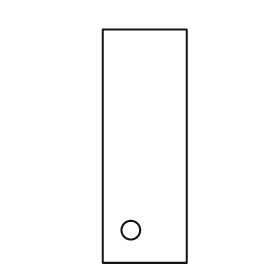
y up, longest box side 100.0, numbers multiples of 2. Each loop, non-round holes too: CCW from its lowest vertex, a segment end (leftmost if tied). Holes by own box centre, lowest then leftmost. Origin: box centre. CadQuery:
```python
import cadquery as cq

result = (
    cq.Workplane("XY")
    .moveTo(-18.0, -50.0)
    .lineTo(18.0, -50.0)
    .lineTo(18.0, 50.0)
    .lineTo(-18.0, 50.0)
    .close()
    .moveTo(-6.0, -36.0)
    .circle(4.0)
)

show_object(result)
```